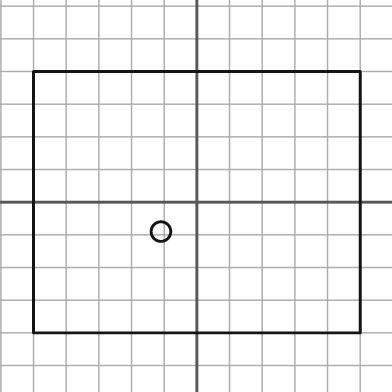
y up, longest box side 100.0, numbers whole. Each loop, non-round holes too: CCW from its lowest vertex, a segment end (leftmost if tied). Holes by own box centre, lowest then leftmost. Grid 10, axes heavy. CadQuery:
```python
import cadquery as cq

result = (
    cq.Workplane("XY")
    .moveTo(-50.0, -40.0)
    .lineTo(50.0, -40.0)
    .lineTo(50.0, 40.0)
    .lineTo(-50.0, 40.0)
    .close()
    .moveTo(-11.0, -9.0)
    .circle(3.0)
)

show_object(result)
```